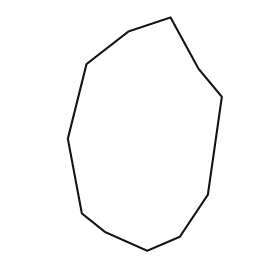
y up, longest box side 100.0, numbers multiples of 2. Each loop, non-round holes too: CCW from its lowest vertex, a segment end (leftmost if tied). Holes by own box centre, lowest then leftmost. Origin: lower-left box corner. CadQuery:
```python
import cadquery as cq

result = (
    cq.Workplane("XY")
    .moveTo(34.0, 0.0)
    .lineTo(48.0, 6.0)
    .lineTo(60.0, 24.0)
    .lineTo(66.0, 66.0)
    .lineTo(56.0, 78.0)
    .lineTo(44.0, 100.0)
    .lineTo(26.0, 94.0)
    .lineTo(8.0, 80.0)
    .lineTo(0.0, 48.0)
    .lineTo(6.0, 16.0)
    .lineTo(16.0, 8.0)
    .close()
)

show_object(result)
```